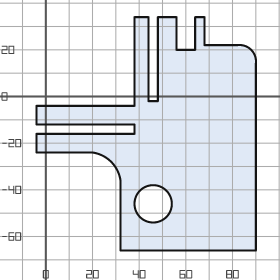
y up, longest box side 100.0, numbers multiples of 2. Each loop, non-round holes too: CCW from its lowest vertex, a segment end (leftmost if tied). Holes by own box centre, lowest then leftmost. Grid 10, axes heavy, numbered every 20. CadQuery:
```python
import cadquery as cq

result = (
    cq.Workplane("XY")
    .moveTo(32.0, -66.0)
    .lineTo(90.0, -66.0)
    .lineTo(90.0, 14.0)
    .threePointArc((88.0, 20.0), (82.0, 22.0))
    .lineTo(68.0, 22.0)
    .lineTo(68.0, 34.0)
    .lineTo(64.0, 34.0)
    .lineTo(64.0, 20.0)
    .lineTo(56.0, 20.0)
    .lineTo(56.0, 34.0)
    .lineTo(48.0, 34.0)
    .lineTo(48.0, -2.0)
    .lineTo(44.0, -2.0)
    .lineTo(44.0, 34.0)
    .lineTo(38.0, 34.0)
    .lineTo(38.0, -4.0)
    .lineTo(-4.0, -4.0)
    .lineTo(-4.0, -12.0)
    .lineTo(38.0, -12.0)
    .lineTo(38.0, -16.0)
    .lineTo(-4.0, -16.0)
    .lineTo(-4.0, -24.0)
    .lineTo(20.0, -24.0)
    .threePointArc((28.0, -28.0), (32.0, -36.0))
    .close()
    .moveTo(46.0, -46.0)
    .circle(8.0)
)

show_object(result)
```